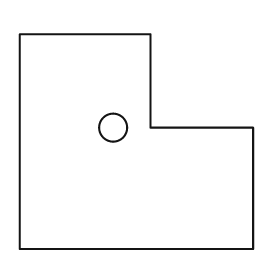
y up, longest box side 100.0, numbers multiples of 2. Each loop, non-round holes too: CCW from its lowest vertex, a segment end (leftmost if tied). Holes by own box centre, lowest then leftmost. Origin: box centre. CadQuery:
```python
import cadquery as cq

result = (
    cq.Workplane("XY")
    .moveTo(-50.0, -46.0)
    .lineTo(50.0, -46.0)
    .lineTo(50.0, 6.0)
    .lineTo(6.0, 6.0)
    .lineTo(6.0, 46.0)
    .lineTo(-50.0, 46.0)
    .close()
    .moveTo(-10.0, 6.0)
    .circle(6.0)
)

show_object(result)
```